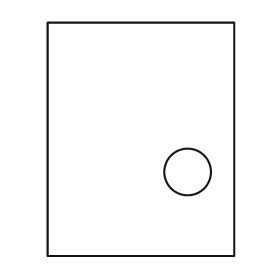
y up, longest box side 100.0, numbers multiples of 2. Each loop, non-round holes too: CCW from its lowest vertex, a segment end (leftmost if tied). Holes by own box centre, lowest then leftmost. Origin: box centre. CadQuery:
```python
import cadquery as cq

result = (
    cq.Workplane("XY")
    .moveTo(-40.0, -50.0)
    .lineTo(40.0, -50.0)
    .lineTo(40.0, 50.0)
    .lineTo(-40.0, 50.0)
    .close()
    .moveTo(20.0, -14.0)
    .circle(10.0)
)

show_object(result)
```